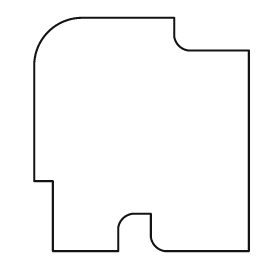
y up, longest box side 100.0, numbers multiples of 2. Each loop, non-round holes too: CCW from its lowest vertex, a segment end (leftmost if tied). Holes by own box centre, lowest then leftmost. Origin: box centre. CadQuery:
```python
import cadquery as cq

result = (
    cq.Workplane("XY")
    .moveTo(-38.0, -50.0)
    .lineTo(-10.0, -50.0)
    .lineTo(-10.0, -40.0)
    .threePointArc((-8.0, -36.0), (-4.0, -34.0))
    .lineTo(4.0, -34.0)
    .lineTo(4.0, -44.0)
    .threePointArc((6.0, -48.0), (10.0, -50.0))
    .lineTo(46.0, -50.0)
    .lineTo(46.0, 36.0)
    .lineTo(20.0, 36.0)
    .threePointArc((16.0, 38.0), (14.0, 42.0))
    .lineTo(14.0, 50.0)
    .lineTo(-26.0, 50.0)
    .threePointArc((-40.0, 44.0), (-46.0, 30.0))
    .lineTo(-46.0, -20.0)
    .lineTo(-38.0, -20.0)
    .close()
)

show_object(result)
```